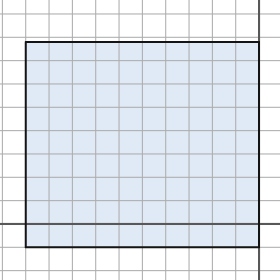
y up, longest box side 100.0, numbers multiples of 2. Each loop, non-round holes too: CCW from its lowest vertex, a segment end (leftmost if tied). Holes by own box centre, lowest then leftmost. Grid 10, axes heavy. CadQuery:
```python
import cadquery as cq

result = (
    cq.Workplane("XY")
    .moveTo(-100.0, -10.0)
    .lineTo(0.0, -10.0)
    .lineTo(0.0, 78.0)
    .lineTo(-100.0, 78.0)
    .close()
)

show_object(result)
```